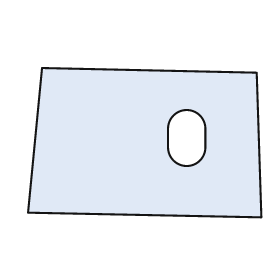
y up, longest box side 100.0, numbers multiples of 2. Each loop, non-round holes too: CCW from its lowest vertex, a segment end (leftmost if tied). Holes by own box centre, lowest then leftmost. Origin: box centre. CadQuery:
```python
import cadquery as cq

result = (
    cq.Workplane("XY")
    .moveTo(50.0, -32.0)
    .lineTo(48.0, 30.0)
    .lineTo(-44.0, 32.0)
    .lineTo(-50.0, -30.0)
    .close()
    .moveTo(10.0, -2.0)
    .threePointArc((18.0, -10.0), (26.0, -2.0))
    .lineTo(26.0, 6.0)
    .threePointArc((18.0, 14.0), (10.0, 6.0))
    .close()
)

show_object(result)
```